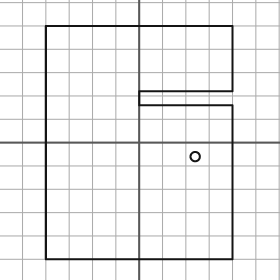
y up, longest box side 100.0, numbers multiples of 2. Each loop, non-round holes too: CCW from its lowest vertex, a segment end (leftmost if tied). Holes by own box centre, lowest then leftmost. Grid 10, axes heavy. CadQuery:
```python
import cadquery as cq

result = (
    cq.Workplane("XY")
    .moveTo(-40.0, -50.0)
    .lineTo(40.0, -50.0)
    .lineTo(40.0, 16.0)
    .lineTo(0.0, 16.0)
    .lineTo(0.0, 22.0)
    .lineTo(40.0, 22.0)
    .lineTo(40.0, 50.0)
    .lineTo(-40.0, 50.0)
    .close()
    .moveTo(24.0, -6.0)
    .circle(2.0)
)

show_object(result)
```